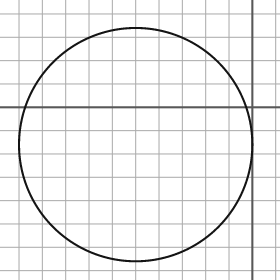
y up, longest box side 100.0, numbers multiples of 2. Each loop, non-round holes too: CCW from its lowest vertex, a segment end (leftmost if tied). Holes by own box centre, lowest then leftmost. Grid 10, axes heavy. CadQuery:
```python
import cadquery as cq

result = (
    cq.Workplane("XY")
    .moveTo(-50.0, -16.0)
    .circle(50.0)
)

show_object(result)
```